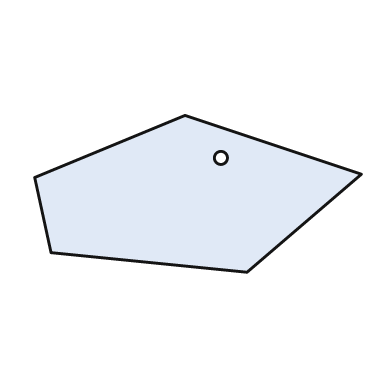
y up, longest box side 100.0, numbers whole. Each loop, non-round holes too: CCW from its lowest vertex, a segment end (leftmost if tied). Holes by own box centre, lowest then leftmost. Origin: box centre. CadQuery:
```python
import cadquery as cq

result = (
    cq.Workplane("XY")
    .moveTo(15.0, -24.0)
    .lineTo(50.0, 6.0)
    .lineTo(-4.0, 24.0)
    .lineTo(-50.0, 5.0)
    .lineTo(-45.0, -18.0)
    .close()
    .moveTo(7.0, 11.0)
    .circle(2.0)
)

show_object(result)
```